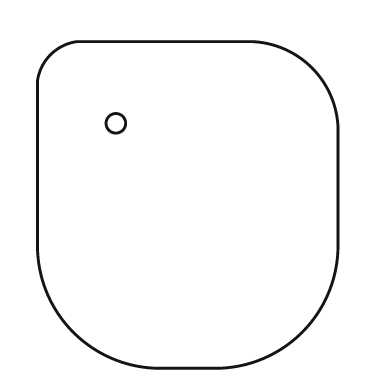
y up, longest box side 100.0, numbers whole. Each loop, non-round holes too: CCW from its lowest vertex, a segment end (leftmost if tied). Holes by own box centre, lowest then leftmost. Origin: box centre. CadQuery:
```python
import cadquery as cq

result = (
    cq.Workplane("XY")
    .moveTo(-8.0, -50.0)
    .lineTo(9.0, -50.0)
    .threePointArc((35.0, -39.0), (46.0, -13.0))
    .lineTo(46.0, 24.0)
    .threePointArc((38.0, 42.0), (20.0, 50.0))
    .lineTo(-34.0, 50.0)
    .threePointArc((-42.0, 46.0), (-46.0, 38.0))
    .lineTo(-46.0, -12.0)
    .threePointArc((-35.0, -39.0), (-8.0, -50.0))
    .close()
    .moveTo(-22.0, 25.0)
    .circle(3.0)
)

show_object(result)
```